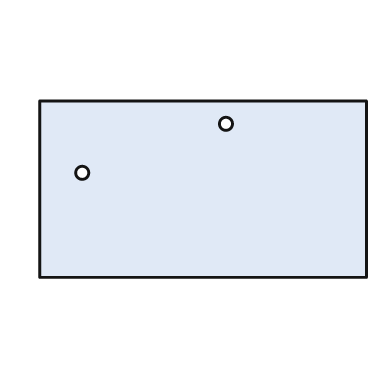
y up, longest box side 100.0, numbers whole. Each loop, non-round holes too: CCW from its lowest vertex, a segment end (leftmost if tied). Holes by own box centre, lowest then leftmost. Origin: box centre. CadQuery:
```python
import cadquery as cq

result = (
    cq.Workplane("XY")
    .moveTo(-50.0, -27.0)
    .lineTo(50.0, -27.0)
    .lineTo(50.0, 27.0)
    .lineTo(-50.0, 27.0)
    .close()
    .moveTo(-37.0, 5.0)
    .circle(2.0)
    .moveTo(7.0, 20.0)
    .circle(2.0)
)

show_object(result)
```